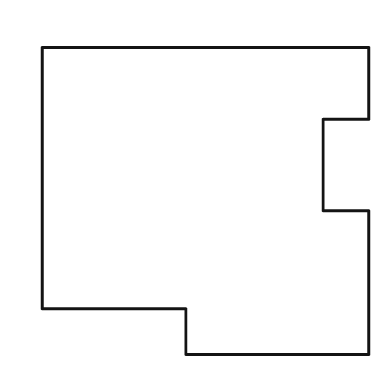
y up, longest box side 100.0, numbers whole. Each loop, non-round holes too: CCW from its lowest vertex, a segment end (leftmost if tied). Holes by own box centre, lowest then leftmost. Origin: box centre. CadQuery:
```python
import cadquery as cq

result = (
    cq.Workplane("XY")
    .moveTo(-6.0, -47.0)
    .lineTo(50.0, -47.0)
    .lineTo(50.0, -3.0)
    .lineTo(36.0, -3.0)
    .lineTo(36.0, 25.0)
    .lineTo(50.0, 25.0)
    .lineTo(50.0, 47.0)
    .lineTo(-50.0, 47.0)
    .lineTo(-50.0, -33.0)
    .lineTo(-6.0, -33.0)
    .close()
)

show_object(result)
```